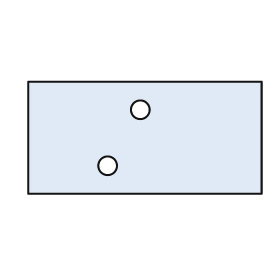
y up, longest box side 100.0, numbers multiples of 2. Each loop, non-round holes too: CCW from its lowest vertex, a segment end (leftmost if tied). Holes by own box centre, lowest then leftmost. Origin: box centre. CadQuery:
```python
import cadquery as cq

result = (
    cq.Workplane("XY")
    .moveTo(-50.0, -24.0)
    .lineTo(50.0, -24.0)
    .lineTo(50.0, 24.0)
    .lineTo(-50.0, 24.0)
    .close()
    .moveTo(-16.0, -12.0)
    .circle(4.0)
    .moveTo(-2.0, 12.0)
    .circle(4.0)
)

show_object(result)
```